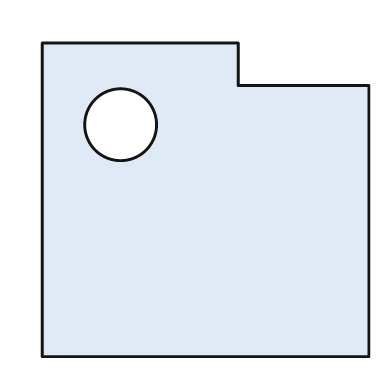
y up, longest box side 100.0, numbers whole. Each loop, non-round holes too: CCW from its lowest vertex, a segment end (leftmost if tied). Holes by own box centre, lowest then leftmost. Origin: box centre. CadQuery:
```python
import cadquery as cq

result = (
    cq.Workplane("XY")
    .moveTo(-50.0, -48.0)
    .lineTo(50.0, -48.0)
    .lineTo(50.0, 35.0)
    .lineTo(10.0, 35.0)
    .lineTo(10.0, 48.0)
    .lineTo(-50.0, 48.0)
    .close()
    .moveTo(-26.0, 23.0)
    .circle(11.0)
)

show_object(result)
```